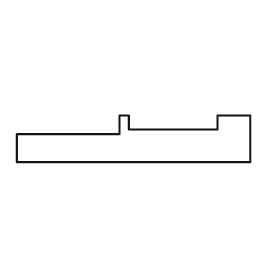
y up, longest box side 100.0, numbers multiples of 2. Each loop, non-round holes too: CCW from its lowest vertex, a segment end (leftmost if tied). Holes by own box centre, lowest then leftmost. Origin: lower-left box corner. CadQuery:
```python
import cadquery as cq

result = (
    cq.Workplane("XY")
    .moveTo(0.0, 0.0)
    .lineTo(100.0, 0.0)
    .lineTo(100.0, 20.0)
    .lineTo(86.0, 20.0)
    .lineTo(86.0, 14.0)
    .lineTo(48.0, 14.0)
    .lineTo(48.0, 20.0)
    .lineTo(44.0, 20.0)
    .lineTo(44.0, 12.0)
    .lineTo(0.0, 12.0)
    .close()
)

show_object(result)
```